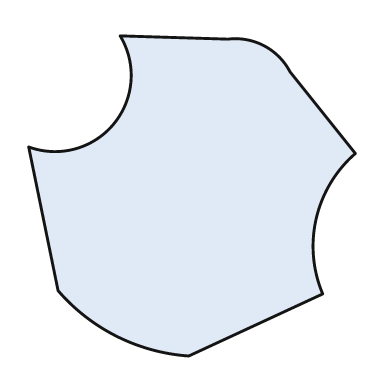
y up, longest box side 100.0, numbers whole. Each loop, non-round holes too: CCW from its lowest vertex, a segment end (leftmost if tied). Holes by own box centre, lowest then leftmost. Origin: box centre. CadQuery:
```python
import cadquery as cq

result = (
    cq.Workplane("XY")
    .moveTo(-1.0, -49.0)
    .lineTo(40.0, -30.0)
    .threePointArc((38.0, -7.0), (50.0, 13.0))
    .lineTo(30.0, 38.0)
    .threePointArc((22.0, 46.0), (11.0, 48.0))
    .lineTo(-22.0, 49.0)
    .threePointArc((-24.0, 22.0), (-50.0, 15.0))
    .lineTo(-41.0, -29.0)
    .threePointArc((-23.0, -43.0), (-1.0, -49.0))
    .close()
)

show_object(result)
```